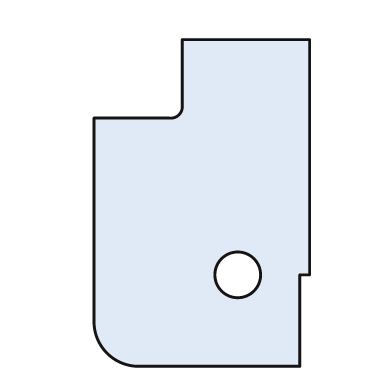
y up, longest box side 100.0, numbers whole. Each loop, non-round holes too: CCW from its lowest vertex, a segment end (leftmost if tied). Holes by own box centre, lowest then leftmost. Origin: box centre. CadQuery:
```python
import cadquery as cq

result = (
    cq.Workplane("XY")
    .moveTo(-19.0, -50.0)
    .lineTo(30.0, -50.0)
    .lineTo(30.0, -22.0)
    .lineTo(33.0, -22.0)
    .lineTo(33.0, 50.0)
    .lineTo(-6.0, 50.0)
    .lineTo(-6.0, 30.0)
    .threePointArc((-7.0, 27.0), (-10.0, 26.0))
    .lineTo(-33.0, 26.0)
    .lineTo(-33.0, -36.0)
    .threePointArc((-29.0, -46.0), (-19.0, -50.0))
    .close()
    .moveTo(11.0, -22.0)
    .circle(7.0)
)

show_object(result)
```